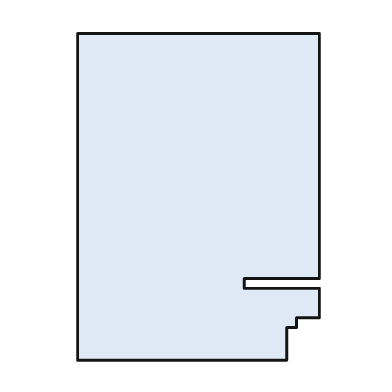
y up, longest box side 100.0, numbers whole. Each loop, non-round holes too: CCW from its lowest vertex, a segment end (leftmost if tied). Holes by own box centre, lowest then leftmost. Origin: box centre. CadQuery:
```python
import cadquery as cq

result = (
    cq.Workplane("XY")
    .moveTo(-37.0, -50.0)
    .lineTo(27.0, -50.0)
    .lineTo(27.0, -40.0)
    .lineTo(30.0, -40.0)
    .lineTo(30.0, -37.0)
    .lineTo(37.0, -37.0)
    .lineTo(37.0, -28.0)
    .lineTo(14.0, -28.0)
    .lineTo(14.0, -25.0)
    .lineTo(37.0, -25.0)
    .lineTo(37.0, 50.0)
    .lineTo(-37.0, 50.0)
    .close()
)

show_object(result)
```